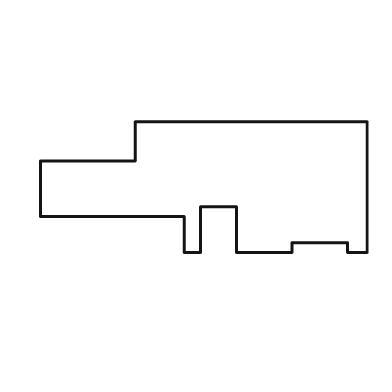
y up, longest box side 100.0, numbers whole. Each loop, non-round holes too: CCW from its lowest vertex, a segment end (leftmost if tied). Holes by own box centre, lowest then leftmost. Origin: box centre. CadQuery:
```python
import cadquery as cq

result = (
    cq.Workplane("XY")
    .moveTo(-6.0, -20.0)
    .lineTo(-1.0, -20.0)
    .lineTo(-1.0, -6.0)
    .lineTo(10.0, -6.0)
    .lineTo(10.0, -20.0)
    .lineTo(27.0, -20.0)
    .lineTo(27.0, -17.0)
    .lineTo(44.0, -17.0)
    .lineTo(44.0, -20.0)
    .lineTo(50.0, -20.0)
    .lineTo(50.0, 20.0)
    .lineTo(-21.0, 20.0)
    .lineTo(-21.0, 8.0)
    .lineTo(-50.0, 8.0)
    .lineTo(-50.0, -9.0)
    .lineTo(-6.0, -9.0)
    .close()
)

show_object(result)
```